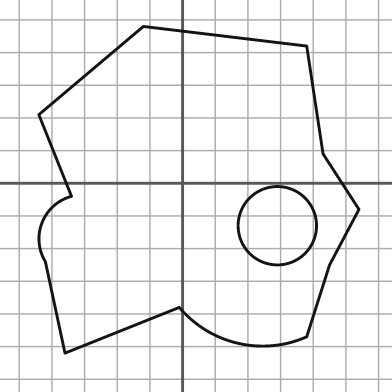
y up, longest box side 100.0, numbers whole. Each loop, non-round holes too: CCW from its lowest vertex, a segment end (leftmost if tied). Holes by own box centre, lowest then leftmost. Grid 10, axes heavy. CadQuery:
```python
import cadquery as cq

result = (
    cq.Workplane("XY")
    .moveTo(-36.0, -52.0)
    .lineTo(-1.0, -38.0)
    .threePointArc((17.0, -49.0), (38.0, -47.0))
    .lineTo(45.0, -25.0)
    .lineTo(54.0, -8.0)
    .lineTo(43.0, 9.0)
    .lineTo(38.0, 42.0)
    .lineTo(-12.0, 48.0)
    .lineTo(-44.0, 21.0)
    .lineTo(-34.0, -4.0)
    .threePointArc((-43.0, -12.0), (-42.0, -24.0))
    .close()
    .moveTo(29.0, -13.0)
    .circle(12.0)
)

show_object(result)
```